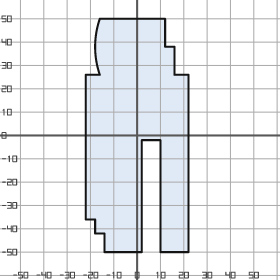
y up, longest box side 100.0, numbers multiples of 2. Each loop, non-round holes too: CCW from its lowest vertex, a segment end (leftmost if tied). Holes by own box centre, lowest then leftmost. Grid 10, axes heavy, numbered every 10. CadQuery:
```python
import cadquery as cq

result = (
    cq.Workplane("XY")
    .moveTo(-14.0, -50.0)
    .lineTo(2.0, -50.0)
    .lineTo(2.0, -2.0)
    .lineTo(10.0, -2.0)
    .lineTo(10.0, -50.0)
    .lineTo(22.0, -50.0)
    .lineTo(22.0, 26.0)
    .lineTo(16.0, 26.0)
    .lineTo(16.0, 38.0)
    .lineTo(12.0, 38.0)
    .lineTo(12.0, 50.0)
    .lineTo(-16.0, 50.0)
    .threePointArc((-18.0, 38.0), (-16.0, 26.0))
    .lineTo(-22.0, 26.0)
    .lineTo(-22.0, -36.0)
    .lineTo(-18.0, -36.0)
    .lineTo(-18.0, -42.0)
    .lineTo(-14.0, -42.0)
    .close()
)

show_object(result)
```